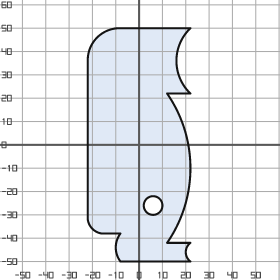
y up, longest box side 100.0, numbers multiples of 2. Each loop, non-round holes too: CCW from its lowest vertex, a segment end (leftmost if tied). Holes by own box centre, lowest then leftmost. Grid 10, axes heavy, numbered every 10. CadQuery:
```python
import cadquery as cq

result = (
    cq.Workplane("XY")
    .moveTo(-8.0, -50.0)
    .lineTo(22.0, -50.0)
    .threePointArc((20.0, -46.0), (22.0, -42.0))
    .lineTo(12.0, -42.0)
    .threePointArc((22.0, -10.0), (12.0, 22.0))
    .lineTo(22.0, 22.0)
    .threePointArc((16.0, 36.0), (22.0, 50.0))
    .lineTo(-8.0, 50.0)
    .threePointArc((-18.0, 46.0), (-22.0, 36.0))
    .lineTo(-22.0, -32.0)
    .threePointArc((-20.0, -36.0), (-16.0, -38.0))
    .lineTo(-8.0, -38.0)
    .threePointArc((-10.0, -44.0), (-8.0, -50.0))
    .close()
    .moveTo(6.0, -26.0)
    .circle(4.0)
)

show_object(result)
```